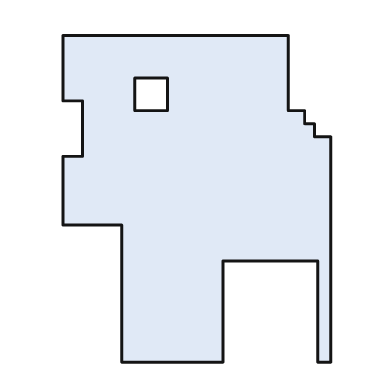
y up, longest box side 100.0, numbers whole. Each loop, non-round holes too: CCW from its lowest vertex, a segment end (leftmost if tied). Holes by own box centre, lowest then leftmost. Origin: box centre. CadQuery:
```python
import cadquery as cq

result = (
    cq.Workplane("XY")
    .moveTo(-23.0, -50.0)
    .lineTo(8.0, -50.0)
    .lineTo(8.0, -19.0)
    .lineTo(37.0, -19.0)
    .lineTo(37.0, -50.0)
    .lineTo(41.0, -50.0)
    .lineTo(41.0, 19.0)
    .lineTo(36.0, 19.0)
    .lineTo(36.0, 23.0)
    .lineTo(33.0, 23.0)
    .lineTo(33.0, 27.0)
    .lineTo(28.0, 27.0)
    .lineTo(28.0, 50.0)
    .lineTo(-41.0, 50.0)
    .lineTo(-41.0, 30.0)
    .lineTo(-35.0, 30.0)
    .lineTo(-35.0, 13.0)
    .lineTo(-41.0, 13.0)
    .lineTo(-41.0, -8.0)
    .lineTo(-23.0, -8.0)
    .close()
    .moveTo(-19.0, 27.0)
    .lineTo(-9.0, 27.0)
    .lineTo(-9.0, 37.0)
    .lineTo(-19.0, 37.0)
    .close()
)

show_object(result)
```